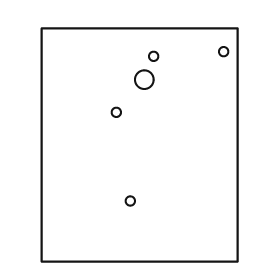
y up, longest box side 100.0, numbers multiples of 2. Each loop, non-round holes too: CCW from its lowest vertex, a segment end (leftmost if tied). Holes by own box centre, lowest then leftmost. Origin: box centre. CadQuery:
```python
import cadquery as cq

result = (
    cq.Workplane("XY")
    .moveTo(-42.0, -50.0)
    .lineTo(42.0, -50.0)
    .lineTo(42.0, 50.0)
    .lineTo(-42.0, 50.0)
    .close()
    .moveTo(-4.0, -24.0)
    .circle(2.0)
    .moveTo(-10.0, 14.0)
    .circle(2.0)
    .moveTo(2.0, 28.0)
    .circle(4.0)
    .moveTo(6.0, 38.0)
    .circle(2.0)
    .moveTo(36.0, 40.0)
    .circle(2.0)
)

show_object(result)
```